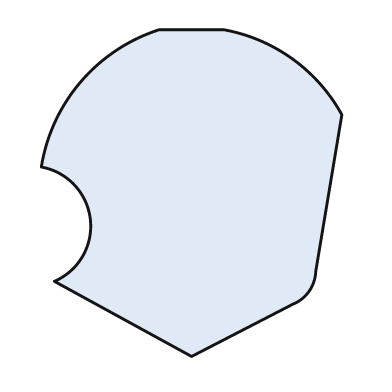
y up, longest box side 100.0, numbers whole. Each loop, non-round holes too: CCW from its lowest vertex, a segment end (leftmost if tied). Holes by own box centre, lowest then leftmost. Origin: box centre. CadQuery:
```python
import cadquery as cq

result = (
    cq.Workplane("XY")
    .moveTo(0.0, -50.0)
    .lineTo(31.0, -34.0)
    .threePointArc((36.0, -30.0), (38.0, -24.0))
    .lineTo(46.0, 24.0)
    .threePointArc((31.0, 41.0), (10.0, 50.0))
    .lineTo(-10.0, 50.0)
    .threePointArc((-34.0, 34.0), (-46.0, 8.0))
    .threePointArc((-31.0, -8.0), (-42.0, -27.0))
    .close()
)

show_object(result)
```